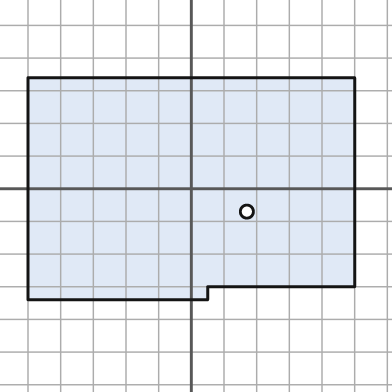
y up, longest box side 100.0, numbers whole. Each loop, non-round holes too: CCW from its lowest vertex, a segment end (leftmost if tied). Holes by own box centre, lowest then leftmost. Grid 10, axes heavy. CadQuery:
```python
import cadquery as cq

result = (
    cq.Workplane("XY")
    .moveTo(-50.0, -34.0)
    .lineTo(5.0, -34.0)
    .lineTo(5.0, -30.0)
    .lineTo(50.0, -30.0)
    .lineTo(50.0, 34.0)
    .lineTo(-50.0, 34.0)
    .close()
    .moveTo(17.0, -7.0)
    .circle(2.0)
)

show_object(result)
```